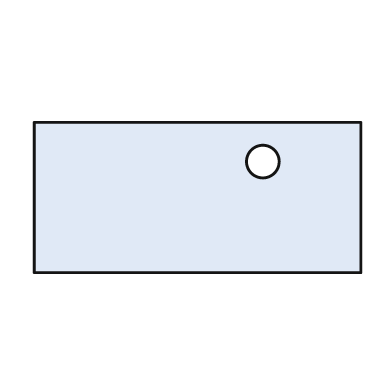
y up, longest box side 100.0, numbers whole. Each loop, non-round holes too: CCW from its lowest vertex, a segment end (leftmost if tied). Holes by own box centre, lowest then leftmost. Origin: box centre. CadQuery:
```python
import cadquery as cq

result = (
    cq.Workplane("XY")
    .moveTo(-50.0, -23.0)
    .lineTo(50.0, -23.0)
    .lineTo(50.0, 23.0)
    .lineTo(-50.0, 23.0)
    .close()
    .moveTo(20.0, 11.0)
    .circle(5.0)
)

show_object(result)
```